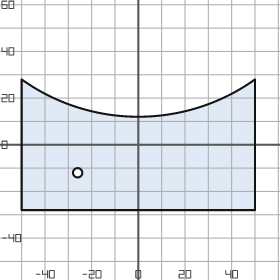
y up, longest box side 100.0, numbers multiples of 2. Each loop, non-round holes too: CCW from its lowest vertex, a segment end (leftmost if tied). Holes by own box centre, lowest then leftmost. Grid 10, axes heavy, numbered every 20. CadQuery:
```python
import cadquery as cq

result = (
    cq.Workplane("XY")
    .moveTo(-50.0, -28.0)
    .lineTo(50.0, -28.0)
    .lineTo(50.0, 28.0)
    .threePointArc((0.0, 12.0), (-50.0, 28.0))
    .close()
    .moveTo(-26.0, -12.0)
    .circle(2.0)
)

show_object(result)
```